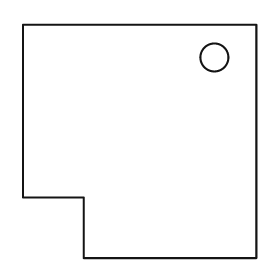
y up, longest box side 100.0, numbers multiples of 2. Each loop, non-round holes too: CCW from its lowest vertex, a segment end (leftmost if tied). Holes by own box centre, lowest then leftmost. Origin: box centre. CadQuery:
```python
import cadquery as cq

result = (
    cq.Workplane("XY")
    .moveTo(-24.0, -50.0)
    .lineTo(50.0, -50.0)
    .lineTo(50.0, 50.0)
    .lineTo(-50.0, 50.0)
    .lineTo(-50.0, -24.0)
    .lineTo(-24.0, -24.0)
    .close()
    .moveTo(32.0, 36.0)
    .circle(6.0)
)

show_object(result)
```